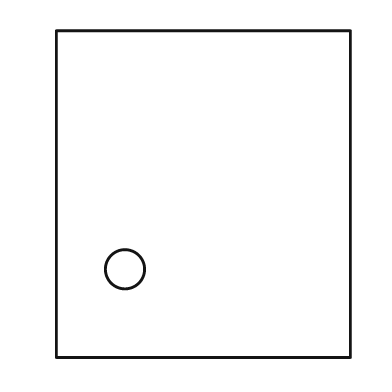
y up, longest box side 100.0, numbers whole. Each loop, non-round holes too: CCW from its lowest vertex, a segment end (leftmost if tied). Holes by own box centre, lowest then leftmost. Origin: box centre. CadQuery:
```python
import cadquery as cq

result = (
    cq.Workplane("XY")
    .moveTo(-45.0, -50.0)
    .lineTo(45.0, -50.0)
    .lineTo(45.0, 50.0)
    .lineTo(-45.0, 50.0)
    .close()
    .moveTo(-24.0, -23.0)
    .circle(6.0)
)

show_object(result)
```